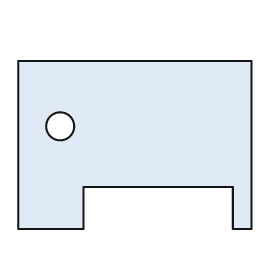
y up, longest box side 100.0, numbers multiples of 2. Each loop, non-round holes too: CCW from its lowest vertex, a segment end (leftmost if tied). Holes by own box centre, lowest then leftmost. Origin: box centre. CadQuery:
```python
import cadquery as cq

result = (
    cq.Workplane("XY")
    .moveTo(-50.0, -36.0)
    .lineTo(-22.0, -36.0)
    .lineTo(-22.0, -18.0)
    .lineTo(42.0, -18.0)
    .lineTo(42.0, -36.0)
    .lineTo(50.0, -36.0)
    .lineTo(50.0, 36.0)
    .lineTo(-50.0, 36.0)
    .close()
    .moveTo(-32.0, 8.0)
    .circle(6.0)
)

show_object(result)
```